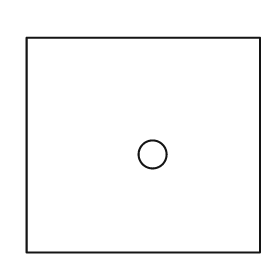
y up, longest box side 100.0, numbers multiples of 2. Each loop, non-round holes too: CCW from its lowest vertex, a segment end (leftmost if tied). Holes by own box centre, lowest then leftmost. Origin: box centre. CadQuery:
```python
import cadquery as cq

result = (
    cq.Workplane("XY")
    .moveTo(-50.0, -46.0)
    .lineTo(50.0, -46.0)
    .lineTo(50.0, 46.0)
    .lineTo(-50.0, 46.0)
    .close()
    .moveTo(4.0, -4.0)
    .circle(6.0)
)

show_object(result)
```